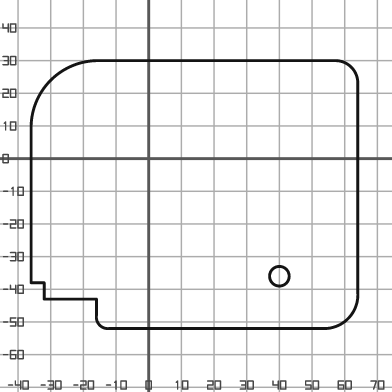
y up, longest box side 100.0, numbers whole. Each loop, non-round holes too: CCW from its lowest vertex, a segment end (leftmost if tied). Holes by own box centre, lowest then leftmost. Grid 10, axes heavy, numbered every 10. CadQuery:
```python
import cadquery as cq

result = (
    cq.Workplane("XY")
    .moveTo(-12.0, -52.0)
    .lineTo(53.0, -52.0)
    .threePointArc((61.0, -49.0), (64.0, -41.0))
    .lineTo(64.0, 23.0)
    .threePointArc((62.0, 28.0), (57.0, 30.0))
    .lineTo(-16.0, 30.0)
    .threePointArc((-30.0, 24.0), (-36.0, 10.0))
    .lineTo(-36.0, -38.0)
    .lineTo(-32.0, -38.0)
    .lineTo(-32.0, -43.0)
    .lineTo(-16.0, -43.0)
    .lineTo(-16.0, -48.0)
    .threePointArc((-15.0, -51.0), (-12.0, -52.0))
    .close()
    .moveTo(40.0, -36.0)
    .circle(3.0)
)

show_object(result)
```